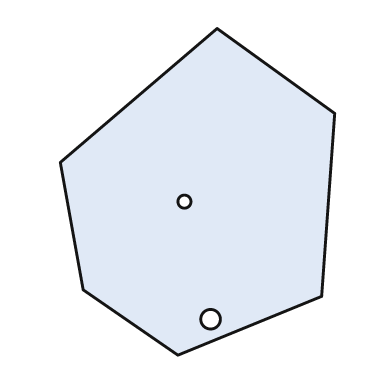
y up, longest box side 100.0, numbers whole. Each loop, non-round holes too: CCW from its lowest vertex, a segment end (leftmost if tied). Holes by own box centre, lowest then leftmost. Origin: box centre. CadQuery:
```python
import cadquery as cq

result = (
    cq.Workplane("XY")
    .moveTo(-6.0, -50.0)
    .lineTo(38.0, -32.0)
    .lineTo(42.0, 24.0)
    .lineTo(6.0, 50.0)
    .lineTo(-42.0, 9.0)
    .lineTo(-35.0, -30.0)
    .close()
    .moveTo(4.0, -39.0)
    .circle(3.0)
    .moveTo(-4.0, -3.0)
    .circle(2.0)
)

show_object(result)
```